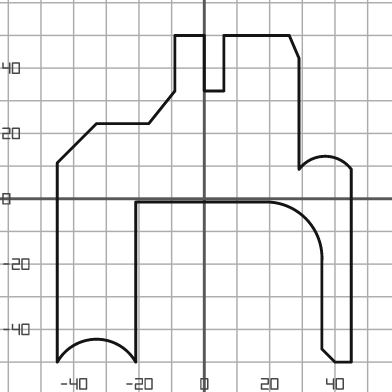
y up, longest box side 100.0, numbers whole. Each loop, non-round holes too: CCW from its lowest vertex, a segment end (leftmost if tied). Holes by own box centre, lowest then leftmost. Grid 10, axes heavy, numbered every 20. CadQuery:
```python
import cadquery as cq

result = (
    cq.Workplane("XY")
    .moveTo(-45.0, -50.0)
    .threePointArc((-33.0, -43.0), (-21.0, -50.0))
    .lineTo(-21.0, -1.0)
    .lineTo(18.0, -1.0)
    .threePointArc((31.0, -6.0), (36.0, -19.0))
    .lineTo(36.0, -46.0)
    .lineTo(40.0, -50.0)
    .lineTo(45.0, -50.0)
    .lineTo(45.0, 9.0)
    .threePointArc((37.0, 13.0), (29.0, 9.0))
    .lineTo(29.0, 43.0)
    .lineTo(26.0, 50.0)
    .lineTo(6.0, 50.0)
    .lineTo(6.0, 33.0)
    .lineTo(0.0, 33.0)
    .lineTo(0.0, 50.0)
    .lineTo(-9.0, 50.0)
    .lineTo(-9.0, 33.0)
    .lineTo(-17.0, 23.0)
    .lineTo(-33.0, 23.0)
    .lineTo(-45.0, 11.0)
    .close()
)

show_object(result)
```